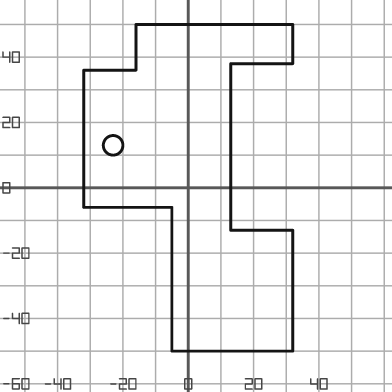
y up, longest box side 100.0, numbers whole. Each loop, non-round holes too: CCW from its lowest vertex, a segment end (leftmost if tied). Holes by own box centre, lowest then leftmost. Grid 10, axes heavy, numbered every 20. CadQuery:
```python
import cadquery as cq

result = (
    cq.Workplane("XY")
    .moveTo(-5.0, -50.0)
    .lineTo(32.0, -50.0)
    .lineTo(32.0, -13.0)
    .lineTo(13.0, -13.0)
    .lineTo(13.0, 38.0)
    .lineTo(32.0, 38.0)
    .lineTo(32.0, 50.0)
    .lineTo(-16.0, 50.0)
    .lineTo(-16.0, 36.0)
    .lineTo(-32.0, 36.0)
    .lineTo(-32.0, -6.0)
    .lineTo(-5.0, -6.0)
    .close()
    .moveTo(-23.0, 13.0)
    .circle(3.0)
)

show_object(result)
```